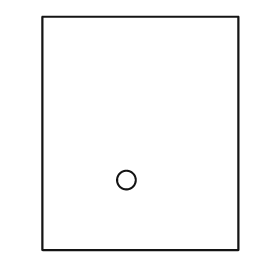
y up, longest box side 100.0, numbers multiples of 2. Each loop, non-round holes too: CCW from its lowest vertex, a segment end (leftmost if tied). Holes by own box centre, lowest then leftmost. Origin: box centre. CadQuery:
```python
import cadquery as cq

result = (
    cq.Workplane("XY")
    .moveTo(-42.0, -50.0)
    .lineTo(42.0, -50.0)
    .lineTo(42.0, 50.0)
    .lineTo(-42.0, 50.0)
    .close()
    .moveTo(-6.0, -20.0)
    .circle(4.0)
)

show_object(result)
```